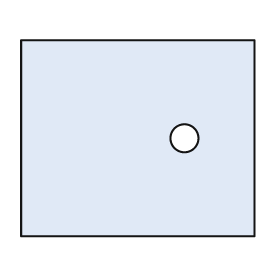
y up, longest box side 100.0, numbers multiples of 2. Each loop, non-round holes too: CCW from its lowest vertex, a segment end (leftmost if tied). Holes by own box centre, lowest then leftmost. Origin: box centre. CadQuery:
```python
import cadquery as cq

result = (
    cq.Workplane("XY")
    .moveTo(-50.0, -42.0)
    .lineTo(50.0, -42.0)
    .lineTo(50.0, 42.0)
    .lineTo(-50.0, 42.0)
    .close()
    .moveTo(20.0, 0.0)
    .circle(6.0)
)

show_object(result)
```